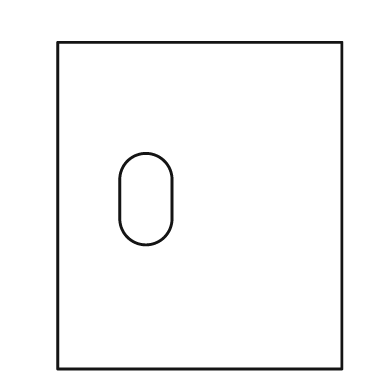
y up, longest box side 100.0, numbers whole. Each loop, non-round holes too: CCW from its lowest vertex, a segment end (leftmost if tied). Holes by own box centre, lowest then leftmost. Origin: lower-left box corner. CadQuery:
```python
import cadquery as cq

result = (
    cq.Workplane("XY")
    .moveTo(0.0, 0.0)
    .lineTo(87.0, 0.0)
    .lineTo(87.0, 100.0)
    .lineTo(0.0, 100.0)
    .close()
    .moveTo(19.0, 46.0)
    .threePointArc((27.0, 38.0), (35.0, 46.0))
    .lineTo(35.0, 58.0)
    .threePointArc((27.0, 66.0), (19.0, 58.0))
    .close()
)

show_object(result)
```